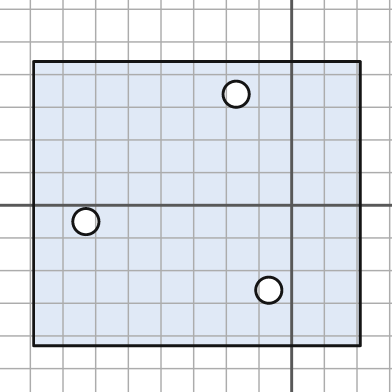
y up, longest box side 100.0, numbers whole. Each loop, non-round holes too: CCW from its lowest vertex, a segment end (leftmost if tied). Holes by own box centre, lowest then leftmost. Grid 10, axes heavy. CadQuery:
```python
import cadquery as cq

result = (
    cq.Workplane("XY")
    .moveTo(-79.0, -43.0)
    .lineTo(21.0, -43.0)
    .lineTo(21.0, 44.0)
    .lineTo(-79.0, 44.0)
    .close()
    .moveTo(-7.0, -26.0)
    .circle(4.0)
    .moveTo(-63.0, -5.0)
    .circle(4.0)
    .moveTo(-17.0, 34.0)
    .circle(4.0)
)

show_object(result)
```